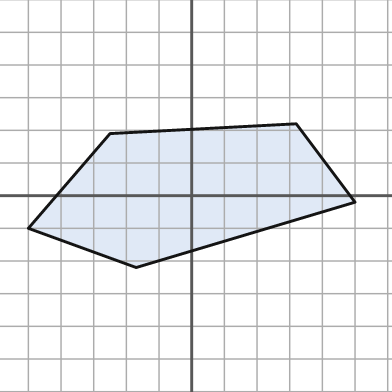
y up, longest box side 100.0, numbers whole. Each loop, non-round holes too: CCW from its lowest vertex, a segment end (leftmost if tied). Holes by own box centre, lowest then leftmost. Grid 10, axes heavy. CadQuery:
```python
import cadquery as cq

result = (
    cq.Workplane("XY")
    .moveTo(-17.0, -22.0)
    .lineTo(50.0, -2.0)
    .lineTo(32.0, 22.0)
    .lineTo(-25.0, 19.0)
    .lineTo(-50.0, -10.0)
    .close()
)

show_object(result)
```